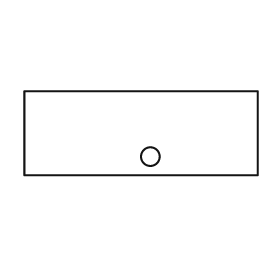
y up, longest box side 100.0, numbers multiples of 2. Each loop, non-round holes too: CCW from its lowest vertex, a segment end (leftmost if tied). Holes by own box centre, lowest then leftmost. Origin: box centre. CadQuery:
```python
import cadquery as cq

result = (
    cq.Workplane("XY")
    .moveTo(-50.0, -18.0)
    .lineTo(50.0, -18.0)
    .lineTo(50.0, 18.0)
    .lineTo(-50.0, 18.0)
    .close()
    .moveTo(4.0, -10.0)
    .circle(4.0)
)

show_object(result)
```